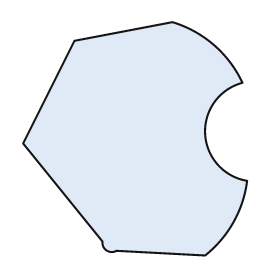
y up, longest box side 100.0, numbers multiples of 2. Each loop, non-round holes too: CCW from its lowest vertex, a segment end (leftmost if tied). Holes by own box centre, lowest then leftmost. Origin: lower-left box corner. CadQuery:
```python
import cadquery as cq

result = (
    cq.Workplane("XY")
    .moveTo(78.0, 0.0)
    .threePointArc((90.0, 14.0), (96.0, 32.0))
    .threePointArc((78.0, 52.0), (94.0, 74.0))
    .threePointArc((82.0, 90.0), (64.0, 100.0))
    .lineTo(22.0, 92.0)
    .lineTo(0.0, 48.0)
    .lineTo(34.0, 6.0)
    .threePointArc((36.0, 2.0), (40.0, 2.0))
    .close()
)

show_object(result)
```